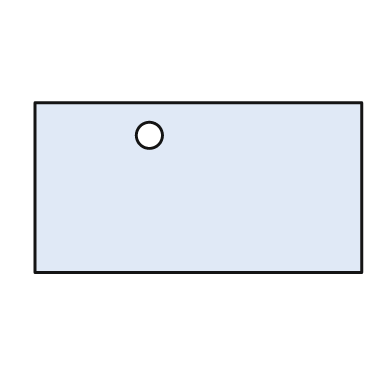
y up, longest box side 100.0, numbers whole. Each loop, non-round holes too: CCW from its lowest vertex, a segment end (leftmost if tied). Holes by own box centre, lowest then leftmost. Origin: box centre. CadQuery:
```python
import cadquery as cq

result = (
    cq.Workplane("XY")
    .moveTo(-50.0, -26.0)
    .lineTo(50.0, -26.0)
    .lineTo(50.0, 26.0)
    .lineTo(-50.0, 26.0)
    .close()
    .moveTo(-15.0, 16.0)
    .circle(4.0)
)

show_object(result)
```